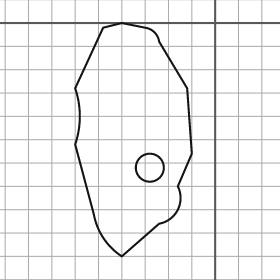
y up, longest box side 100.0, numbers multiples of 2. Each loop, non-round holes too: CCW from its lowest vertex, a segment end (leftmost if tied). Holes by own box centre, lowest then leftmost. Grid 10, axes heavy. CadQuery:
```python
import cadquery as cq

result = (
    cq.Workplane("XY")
    .moveTo(-40.0, -100.0)
    .lineTo(-24.0, -86.0)
    .threePointArc((-16.0, -80.0), (-16.0, -70.0))
    .lineTo(-10.0, -56.0)
    .lineTo(-12.0, -28.0)
    .lineTo(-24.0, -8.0)
    .threePointArc((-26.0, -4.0), (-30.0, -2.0))
    .lineTo(-40.0, 0.0)
    .lineTo(-48.0, -2.0)
    .lineTo(-60.0, -28.0)
    .threePointArc((-58.0, -40.0), (-60.0, -52.0))
    .lineTo(-52.0, -82.0)
    .threePointArc((-48.0, -92.0), (-40.0, -100.0))
    .close()
    .moveTo(-28.0, -62.0)
    .circle(6.0)
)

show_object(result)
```